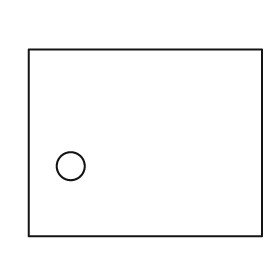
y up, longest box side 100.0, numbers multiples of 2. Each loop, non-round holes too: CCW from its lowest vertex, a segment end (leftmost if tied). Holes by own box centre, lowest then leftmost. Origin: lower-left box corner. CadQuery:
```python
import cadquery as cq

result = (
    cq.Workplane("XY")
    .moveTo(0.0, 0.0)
    .lineTo(100.0, 0.0)
    .lineTo(100.0, 80.0)
    .lineTo(0.0, 80.0)
    .close()
    .moveTo(18.0, 30.0)
    .circle(6.0)
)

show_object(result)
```